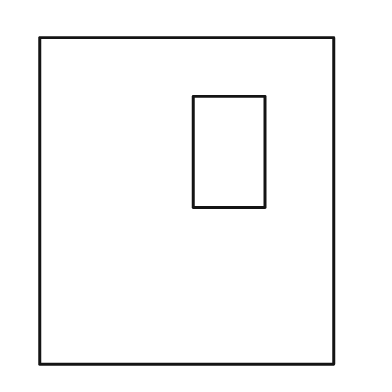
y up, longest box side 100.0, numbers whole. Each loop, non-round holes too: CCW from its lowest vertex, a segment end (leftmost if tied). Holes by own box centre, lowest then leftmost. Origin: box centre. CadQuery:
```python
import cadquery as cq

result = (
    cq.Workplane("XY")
    .moveTo(-45.0, -50.0)
    .lineTo(45.0, -50.0)
    .lineTo(45.0, 50.0)
    .lineTo(-45.0, 50.0)
    .close()
    .moveTo(2.0, -2.0)
    .lineTo(24.0, -2.0)
    .lineTo(24.0, 32.0)
    .lineTo(2.0, 32.0)
    .close()
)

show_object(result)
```